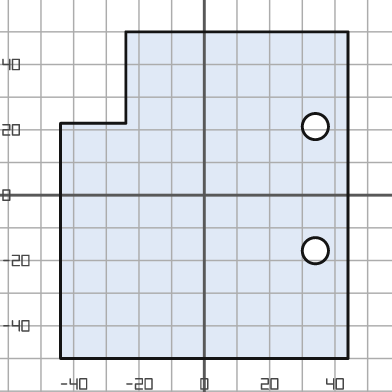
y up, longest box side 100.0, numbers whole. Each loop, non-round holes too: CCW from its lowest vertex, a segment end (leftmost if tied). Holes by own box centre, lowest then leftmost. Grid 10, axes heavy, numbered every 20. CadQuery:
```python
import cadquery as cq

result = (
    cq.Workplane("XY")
    .moveTo(-44.0, -50.0)
    .lineTo(44.0, -50.0)
    .lineTo(44.0, 50.0)
    .lineTo(-24.0, 50.0)
    .lineTo(-24.0, 22.0)
    .lineTo(-44.0, 22.0)
    .close()
    .moveTo(34.0, -17.0)
    .circle(4.0)
    .moveTo(34.0, 21.0)
    .circle(4.0)
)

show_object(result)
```